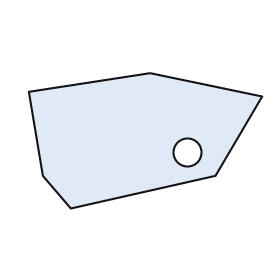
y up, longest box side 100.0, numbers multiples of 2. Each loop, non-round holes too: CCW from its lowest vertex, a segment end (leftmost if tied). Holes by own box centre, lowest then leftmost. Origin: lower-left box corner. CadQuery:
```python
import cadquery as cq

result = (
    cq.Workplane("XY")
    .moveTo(18.0, 0.0)
    .lineTo(80.0, 14.0)
    .lineTo(100.0, 48.0)
    .lineTo(52.0, 58.0)
    .lineTo(0.0, 50.0)
    .lineTo(6.0, 14.0)
    .close()
    .moveTo(68.0, 24.0)
    .circle(6.0)
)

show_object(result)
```